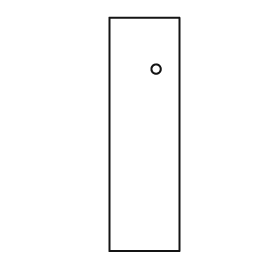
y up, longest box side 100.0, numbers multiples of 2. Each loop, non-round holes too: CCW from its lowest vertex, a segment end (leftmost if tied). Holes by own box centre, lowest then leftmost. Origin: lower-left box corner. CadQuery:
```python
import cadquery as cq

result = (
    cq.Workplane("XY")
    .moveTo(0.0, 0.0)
    .lineTo(30.0, 0.0)
    .lineTo(30.0, 100.0)
    .lineTo(0.0, 100.0)
    .close()
    .moveTo(20.0, 78.0)
    .circle(2.0)
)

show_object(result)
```